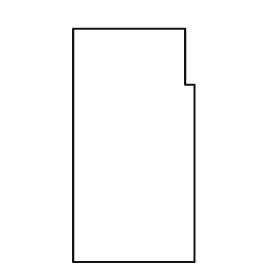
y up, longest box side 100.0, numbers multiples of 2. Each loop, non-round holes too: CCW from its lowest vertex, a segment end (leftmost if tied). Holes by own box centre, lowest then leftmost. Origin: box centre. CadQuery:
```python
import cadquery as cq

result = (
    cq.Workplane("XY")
    .moveTo(-26.0, -50.0)
    .lineTo(26.0, -50.0)
    .lineTo(26.0, 26.0)
    .lineTo(22.0, 26.0)
    .lineTo(22.0, 50.0)
    .lineTo(-26.0, 50.0)
    .close()
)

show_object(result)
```